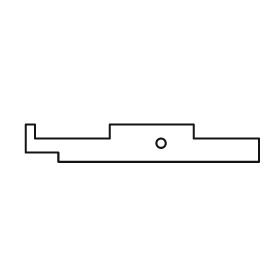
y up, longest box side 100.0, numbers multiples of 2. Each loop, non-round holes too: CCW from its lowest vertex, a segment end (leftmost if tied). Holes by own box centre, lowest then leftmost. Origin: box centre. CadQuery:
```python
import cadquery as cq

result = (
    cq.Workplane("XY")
    .moveTo(-36.0, -8.0)
    .lineTo(50.0, -8.0)
    .lineTo(50.0, 2.0)
    .lineTo(22.0, 2.0)
    .lineTo(22.0, 8.0)
    .lineTo(-14.0, 8.0)
    .lineTo(-14.0, 2.0)
    .lineTo(-46.0, 2.0)
    .lineTo(-46.0, 8.0)
    .lineTo(-50.0, 8.0)
    .lineTo(-50.0, -4.0)
    .lineTo(-36.0, -4.0)
    .close()
    .moveTo(8.0, 0.0)
    .circle(2.0)
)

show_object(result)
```